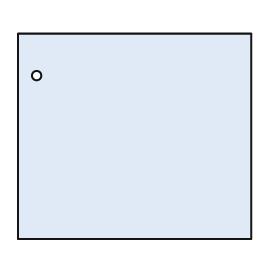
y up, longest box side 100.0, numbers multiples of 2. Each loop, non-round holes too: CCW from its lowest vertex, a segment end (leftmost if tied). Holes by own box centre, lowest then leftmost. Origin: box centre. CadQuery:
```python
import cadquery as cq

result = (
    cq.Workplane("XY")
    .moveTo(-50.0, -44.0)
    .lineTo(50.0, -44.0)
    .lineTo(50.0, 44.0)
    .lineTo(-50.0, 44.0)
    .close()
    .moveTo(-42.0, 26.0)
    .circle(2.0)
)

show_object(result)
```